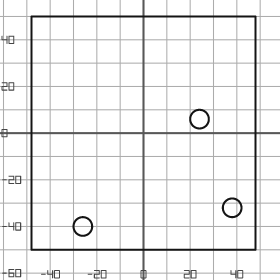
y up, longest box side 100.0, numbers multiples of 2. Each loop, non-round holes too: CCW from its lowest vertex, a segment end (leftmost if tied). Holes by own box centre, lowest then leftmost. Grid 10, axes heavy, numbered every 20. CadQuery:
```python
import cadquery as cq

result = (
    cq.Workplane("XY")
    .moveTo(-48.0, -50.0)
    .lineTo(48.0, -50.0)
    .lineTo(48.0, 50.0)
    .lineTo(-48.0, 50.0)
    .close()
    .moveTo(-26.0, -40.0)
    .circle(4.0)
    .moveTo(38.0, -32.0)
    .circle(4.0)
    .moveTo(24.0, 6.0)
    .circle(4.0)
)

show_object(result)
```